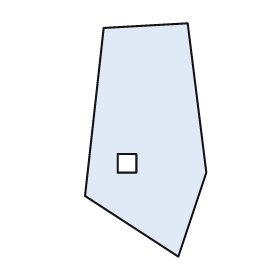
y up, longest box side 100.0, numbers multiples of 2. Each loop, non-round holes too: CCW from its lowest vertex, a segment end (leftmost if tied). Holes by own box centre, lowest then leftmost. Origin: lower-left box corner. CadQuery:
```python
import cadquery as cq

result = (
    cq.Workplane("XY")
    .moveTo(40.0, 0.0)
    .lineTo(52.0, 36.0)
    .lineTo(44.0, 100.0)
    .lineTo(8.0, 98.0)
    .lineTo(0.0, 26.0)
    .close()
    .moveTo(14.0, 36.0)
    .lineTo(22.0, 36.0)
    .lineTo(22.0, 44.0)
    .lineTo(14.0, 44.0)
    .close()
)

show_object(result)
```